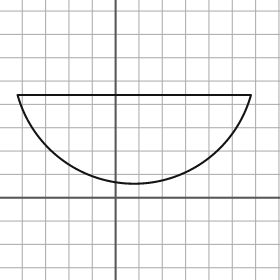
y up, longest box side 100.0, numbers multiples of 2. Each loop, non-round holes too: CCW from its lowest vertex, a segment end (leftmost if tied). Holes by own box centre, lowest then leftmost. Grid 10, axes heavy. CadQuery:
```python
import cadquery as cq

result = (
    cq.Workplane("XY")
    .moveTo(-42.0, 44.0)
    .threePointArc((8.0, 6.0), (58.0, 44.0))
    .close()
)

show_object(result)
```